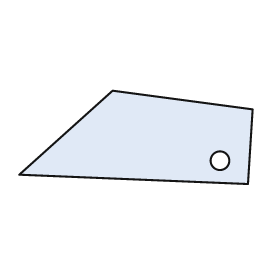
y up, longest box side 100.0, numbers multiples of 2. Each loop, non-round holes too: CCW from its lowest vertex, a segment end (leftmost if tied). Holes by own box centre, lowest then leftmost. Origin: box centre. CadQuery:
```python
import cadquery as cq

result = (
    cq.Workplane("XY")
    .moveTo(48.0, -20.0)
    .lineTo(50.0, 12.0)
    .lineTo(-10.0, 20.0)
    .lineTo(-50.0, -16.0)
    .close()
    .moveTo(36.0, -10.0)
    .circle(4.0)
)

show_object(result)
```